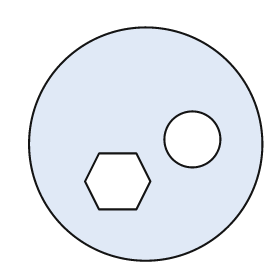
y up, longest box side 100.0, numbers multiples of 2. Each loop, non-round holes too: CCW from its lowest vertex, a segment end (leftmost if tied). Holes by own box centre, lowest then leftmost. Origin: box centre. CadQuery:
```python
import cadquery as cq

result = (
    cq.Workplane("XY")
    .moveTo(0.0, 0.0)
    .circle(50.0)
    .moveTo(-20.0, -28.0)
    .lineTo(-4.0, -28.0)
    .lineTo(2.0, -16.0)
    .lineTo(-4.0, -4.0)
    .lineTo(-20.0, -4.0)
    .lineTo(-26.0, -16.0)
    .close()
    .moveTo(20.0, 2.0)
    .circle(12.0)
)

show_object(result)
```